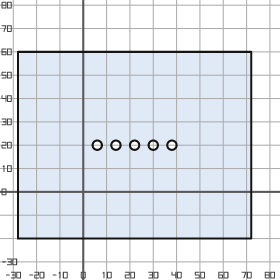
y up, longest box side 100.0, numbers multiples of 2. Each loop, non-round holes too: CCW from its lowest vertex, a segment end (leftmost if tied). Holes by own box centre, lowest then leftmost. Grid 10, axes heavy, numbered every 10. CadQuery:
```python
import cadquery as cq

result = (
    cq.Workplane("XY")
    .moveTo(-28.0, -20.0)
    .lineTo(72.0, -20.0)
    .lineTo(72.0, 60.0)
    .lineTo(-28.0, 60.0)
    .close()
    .moveTo(6.0, 20.0)
    .circle(2.0)
    .moveTo(14.0, 20.0)
    .circle(2.0)
    .moveTo(22.0, 20.0)
    .circle(2.0)
    .moveTo(30.0, 20.0)
    .circle(2.0)
    .moveTo(38.0, 20.0)
    .circle(2.0)
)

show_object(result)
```